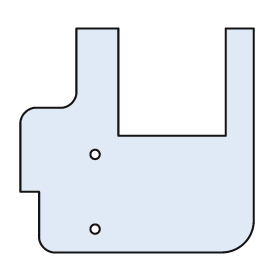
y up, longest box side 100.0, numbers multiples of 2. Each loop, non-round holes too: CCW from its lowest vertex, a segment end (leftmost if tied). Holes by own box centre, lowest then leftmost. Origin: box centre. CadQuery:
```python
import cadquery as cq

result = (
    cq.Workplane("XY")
    .moveTo(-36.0, -48.0)
    .lineTo(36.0, -48.0)
    .threePointArc((46.0, -44.0), (50.0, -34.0))
    .lineTo(50.0, 48.0)
    .lineTo(38.0, 48.0)
    .lineTo(38.0, 2.0)
    .lineTo(-8.0, 2.0)
    .lineTo(-8.0, 48.0)
    .lineTo(-26.0, 48.0)
    .lineTo(-26.0, 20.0)
    .threePointArc((-28.0, 16.0), (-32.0, 14.0))
    .lineTo(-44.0, 14.0)
    .threePointArc((-48.0, 12.0), (-50.0, 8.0))
    .lineTo(-50.0, -22.0)
    .lineTo(-42.0, -22.0)
    .lineTo(-42.0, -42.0)
    .threePointArc((-40.0, -46.0), (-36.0, -48.0))
    .close()
    .moveTo(-18.0, -38.0)
    .circle(2.0)
    .moveTo(-18.0, -6.0)
    .circle(2.0)
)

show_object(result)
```